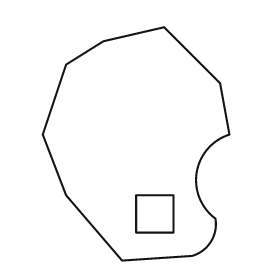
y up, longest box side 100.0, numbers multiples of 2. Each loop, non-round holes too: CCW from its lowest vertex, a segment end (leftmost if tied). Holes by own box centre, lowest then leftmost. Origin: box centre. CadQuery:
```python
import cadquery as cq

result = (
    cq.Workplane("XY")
    .moveTo(-6.0, -50.0)
    .lineTo(24.0, -48.0)
    .threePointArc((32.0, -42.0), (34.0, -32.0))
    .threePointArc((26.0, -12.0), (40.0, 4.0))
    .lineTo(36.0, 26.0)
    .lineTo(12.0, 50.0)
    .lineTo(-14.0, 44.0)
    .lineTo(-30.0, 34.0)
    .lineTo(-40.0, 4.0)
    .lineTo(-30.0, -22.0)
    .close()
    .moveTo(0.0, -38.0)
    .lineTo(16.0, -38.0)
    .lineTo(16.0, -22.0)
    .lineTo(0.0, -22.0)
    .close()
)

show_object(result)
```